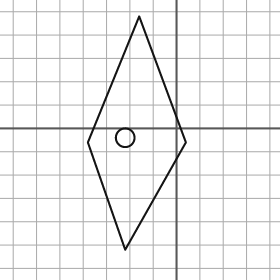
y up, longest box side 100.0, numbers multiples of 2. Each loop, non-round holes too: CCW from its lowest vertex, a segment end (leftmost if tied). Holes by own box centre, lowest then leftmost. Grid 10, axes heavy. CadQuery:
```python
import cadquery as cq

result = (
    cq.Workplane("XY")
    .moveTo(-22.0, -52.0)
    .lineTo(4.0, -6.0)
    .lineTo(-16.0, 48.0)
    .lineTo(-38.0, -6.0)
    .close()
    .moveTo(-22.0, -4.0)
    .circle(4.0)
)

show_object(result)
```